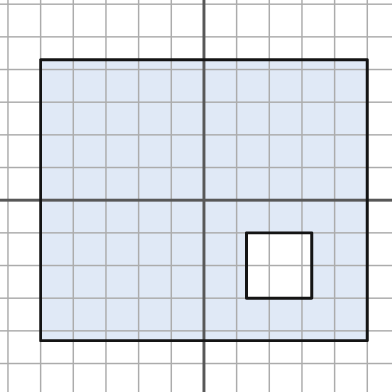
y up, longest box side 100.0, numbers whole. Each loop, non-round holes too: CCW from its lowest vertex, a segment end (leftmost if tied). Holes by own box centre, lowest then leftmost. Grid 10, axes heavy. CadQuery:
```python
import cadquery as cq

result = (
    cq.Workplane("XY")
    .moveTo(-50.0, -43.0)
    .lineTo(50.0, -43.0)
    .lineTo(50.0, 43.0)
    .lineTo(-50.0, 43.0)
    .close()
    .moveTo(13.0, -30.0)
    .lineTo(33.0, -30.0)
    .lineTo(33.0, -10.0)
    .lineTo(13.0, -10.0)
    .close()
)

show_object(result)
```